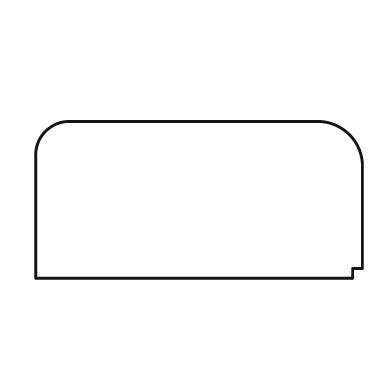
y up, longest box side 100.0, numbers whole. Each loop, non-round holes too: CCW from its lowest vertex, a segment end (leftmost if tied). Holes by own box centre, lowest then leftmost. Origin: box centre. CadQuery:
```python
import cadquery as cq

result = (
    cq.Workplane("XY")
    .moveTo(-50.0, -24.0)
    .lineTo(47.0, -24.0)
    .lineTo(47.0, -21.0)
    .lineTo(50.0, -21.0)
    .lineTo(50.0, 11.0)
    .threePointArc((46.0, 20.0), (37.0, 24.0))
    .lineTo(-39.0, 24.0)
    .threePointArc((-47.0, 21.0), (-50.0, 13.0))
    .close()
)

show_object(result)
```